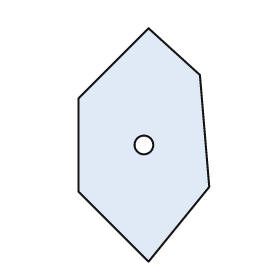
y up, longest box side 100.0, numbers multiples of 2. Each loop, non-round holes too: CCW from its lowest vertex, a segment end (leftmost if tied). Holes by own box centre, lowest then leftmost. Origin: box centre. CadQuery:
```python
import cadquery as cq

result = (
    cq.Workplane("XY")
    .moveTo(2.0, -50.0)
    .lineTo(28.0, -18.0)
    .lineTo(24.0, 30.0)
    .lineTo(2.0, 50.0)
    .lineTo(-28.0, 20.0)
    .lineTo(-28.0, -20.0)
    .close()
    .moveTo(0.0, 0.0)
    .circle(4.0)
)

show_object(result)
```